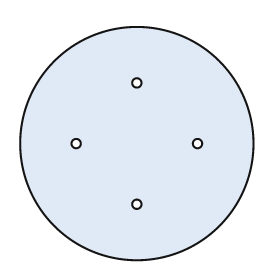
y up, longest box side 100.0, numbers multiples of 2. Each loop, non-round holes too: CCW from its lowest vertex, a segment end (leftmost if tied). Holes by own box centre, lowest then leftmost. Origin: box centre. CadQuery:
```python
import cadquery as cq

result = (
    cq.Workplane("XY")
    .moveTo(0.0, 0.0)
    .circle(50.0)
    .moveTo(0.0, -26.0)
    .circle(2.0)
    .moveTo(-26.0, 0.0)
    .circle(2.0)
    .moveTo(26.0, 0.0)
    .circle(2.0)
    .moveTo(0.0, 26.0)
    .circle(2.0)
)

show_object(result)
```